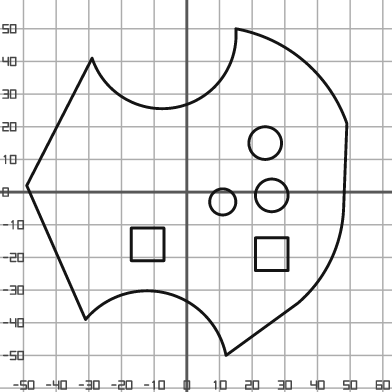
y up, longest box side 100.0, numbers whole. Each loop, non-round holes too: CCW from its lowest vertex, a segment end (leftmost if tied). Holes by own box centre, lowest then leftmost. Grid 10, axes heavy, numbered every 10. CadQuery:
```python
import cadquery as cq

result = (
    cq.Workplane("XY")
    .moveTo(12.0, -50.0)
    .lineTo(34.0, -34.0)
    .threePointArc((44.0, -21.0), (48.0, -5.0))
    .lineTo(49.0, 21.0)
    .threePointArc((36.0, 40.0), (15.0, 50.0))
    .threePointArc((-3.0, 26.0), (-29.0, 41.0))
    .lineTo(-49.0, 2.0)
    .lineTo(-31.0, -39.0)
    .threePointArc((-6.0, -31.0), (12.0, -50.0))
    .close()
    .moveTo(21.0, -24.0)
    .lineTo(31.0, -24.0)
    .lineTo(31.0, -14.0)
    .lineTo(21.0, -14.0)
    .close()
    .moveTo(-17.0, -21.0)
    .lineTo(-7.0, -21.0)
    .lineTo(-7.0, -11.0)
    .lineTo(-17.0, -11.0)
    .close()
    .moveTo(11.0, -3.0)
    .circle(4.0)
    .moveTo(26.0, -1.0)
    .circle(5.0)
    .moveTo(24.0, 15.0)
    .circle(5.0)
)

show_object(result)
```